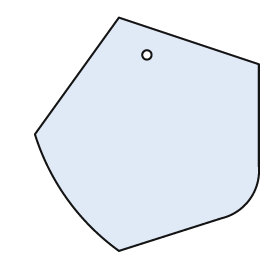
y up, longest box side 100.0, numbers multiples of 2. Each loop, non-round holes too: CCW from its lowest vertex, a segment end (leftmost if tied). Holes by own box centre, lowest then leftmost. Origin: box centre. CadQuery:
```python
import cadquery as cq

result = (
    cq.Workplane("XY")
    .moveTo(-12.0, -50.0)
    .lineTo(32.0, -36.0)
    .threePointArc((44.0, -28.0), (48.0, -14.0))
    .lineTo(48.0, 30.0)
    .lineTo(-12.0, 50.0)
    .lineTo(-48.0, 0.0)
    .threePointArc((-34.0, -28.0), (-12.0, -50.0))
    .close()
    .moveTo(0.0, 34.0)
    .circle(2.0)
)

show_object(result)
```